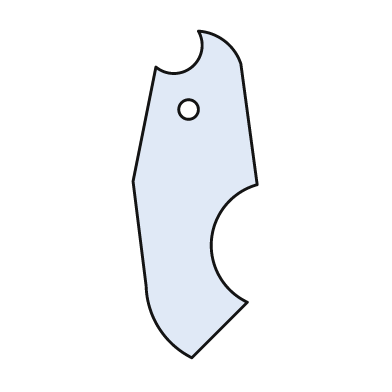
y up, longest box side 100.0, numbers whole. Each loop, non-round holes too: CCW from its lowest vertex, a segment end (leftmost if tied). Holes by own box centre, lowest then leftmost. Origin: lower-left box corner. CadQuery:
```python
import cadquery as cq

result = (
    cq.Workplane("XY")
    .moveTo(18.0, 0.0)
    .lineTo(35.0, 17.0)
    .threePointArc((24.0, 36.0), (38.0, 53.0))
    .lineTo(33.0, 90.0)
    .threePointArc((28.0, 97.0), (20.0, 100.0))
    .threePointArc((18.0, 89.0), (7.0, 89.0))
    .lineTo(0.0, 54.0)
    .lineTo(4.0, 22.0)
    .threePointArc((8.0, 9.0), (18.0, 0.0))
    .close()
    .moveTo(17.0, 76.0)
    .circle(3.0)
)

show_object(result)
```